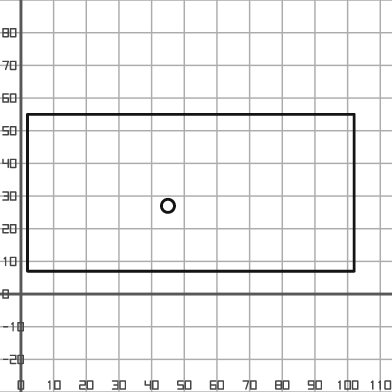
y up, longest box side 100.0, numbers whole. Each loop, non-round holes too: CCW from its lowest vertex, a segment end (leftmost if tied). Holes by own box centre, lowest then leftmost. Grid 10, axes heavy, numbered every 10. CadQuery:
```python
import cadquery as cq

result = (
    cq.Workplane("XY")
    .moveTo(2.0, 7.0)
    .lineTo(102.0, 7.0)
    .lineTo(102.0, 55.0)
    .lineTo(2.0, 55.0)
    .close()
    .moveTo(45.0, 27.0)
    .circle(2.0)
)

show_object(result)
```